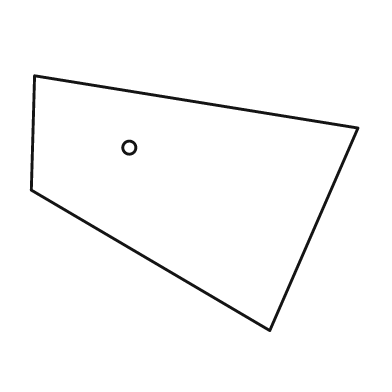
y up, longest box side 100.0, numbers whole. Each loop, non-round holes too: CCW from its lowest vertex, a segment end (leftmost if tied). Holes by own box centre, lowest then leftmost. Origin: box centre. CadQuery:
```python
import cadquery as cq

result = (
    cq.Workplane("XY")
    .moveTo(23.0, -39.0)
    .lineTo(50.0, 23.0)
    .lineTo(-49.0, 39.0)
    .lineTo(-50.0, 4.0)
    .close()
    .moveTo(-20.0, 17.0)
    .circle(2.0)
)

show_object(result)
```